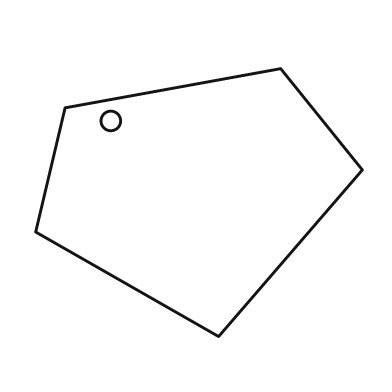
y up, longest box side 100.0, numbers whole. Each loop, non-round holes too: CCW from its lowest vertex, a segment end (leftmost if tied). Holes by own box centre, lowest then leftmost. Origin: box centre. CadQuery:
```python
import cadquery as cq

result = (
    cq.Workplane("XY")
    .moveTo(6.0, -41.0)
    .lineTo(50.0, 10.0)
    .lineTo(25.0, 41.0)
    .lineTo(-41.0, 29.0)
    .lineTo(-50.0, -9.0)
    .close()
    .moveTo(-27.0, 25.0)
    .circle(3.0)
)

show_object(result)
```